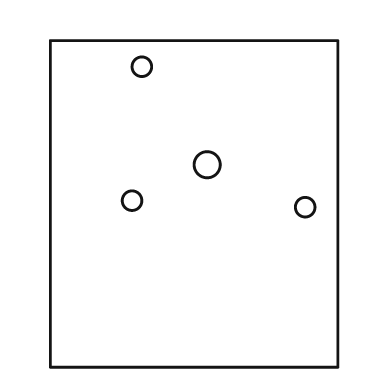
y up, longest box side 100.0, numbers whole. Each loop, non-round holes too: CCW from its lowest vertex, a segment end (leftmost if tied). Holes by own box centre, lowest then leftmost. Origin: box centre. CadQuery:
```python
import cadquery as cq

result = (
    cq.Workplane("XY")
    .moveTo(-44.0, -50.0)
    .lineTo(44.0, -50.0)
    .lineTo(44.0, 50.0)
    .lineTo(-44.0, 50.0)
    .close()
    .moveTo(34.0, -1.0)
    .circle(3.0)
    .moveTo(-19.0, 1.0)
    .circle(3.0)
    .moveTo(4.0, 12.0)
    .circle(4.0)
    .moveTo(-16.0, 42.0)
    .circle(3.0)
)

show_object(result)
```